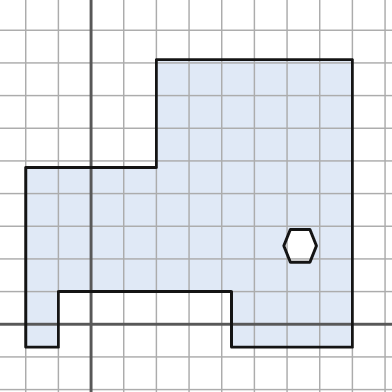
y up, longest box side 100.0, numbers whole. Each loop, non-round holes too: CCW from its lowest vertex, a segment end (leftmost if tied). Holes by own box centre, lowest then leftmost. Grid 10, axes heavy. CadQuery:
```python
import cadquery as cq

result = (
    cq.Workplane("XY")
    .moveTo(-20.0, -7.0)
    .lineTo(-10.0, -7.0)
    .lineTo(-10.0, 10.0)
    .lineTo(43.0, 10.0)
    .lineTo(43.0, -7.0)
    .lineTo(80.0, -7.0)
    .lineTo(80.0, 81.0)
    .lineTo(20.0, 81.0)
    .lineTo(20.0, 48.0)
    .lineTo(-20.0, 48.0)
    .close()
    .moveTo(61.0, 19.0)
    .lineTo(67.0, 19.0)
    .lineTo(69.0, 24.0)
    .lineTo(67.0, 29.0)
    .lineTo(61.0, 29.0)
    .lineTo(59.0, 24.0)
    .close()
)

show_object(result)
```